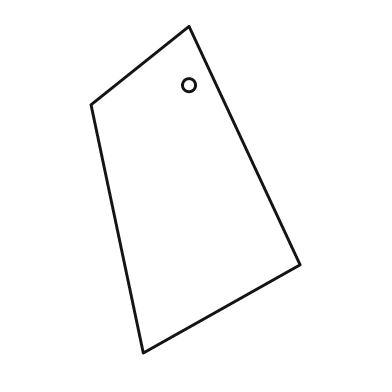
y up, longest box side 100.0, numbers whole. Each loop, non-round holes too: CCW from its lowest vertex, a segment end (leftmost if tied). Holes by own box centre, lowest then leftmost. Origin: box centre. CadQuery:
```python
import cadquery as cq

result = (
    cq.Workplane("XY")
    .moveTo(-16.0, -50.0)
    .lineTo(32.0, -23.0)
    .lineTo(-2.0, 50.0)
    .lineTo(-32.0, 26.0)
    .close()
    .moveTo(-2.0, 32.0)
    .circle(2.0)
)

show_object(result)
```